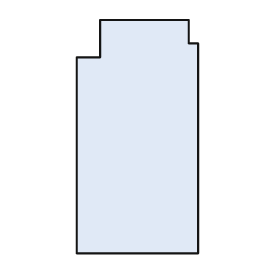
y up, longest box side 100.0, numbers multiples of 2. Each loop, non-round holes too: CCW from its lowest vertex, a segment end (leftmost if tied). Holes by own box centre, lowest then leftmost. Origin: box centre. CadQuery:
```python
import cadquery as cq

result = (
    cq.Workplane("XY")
    .moveTo(-26.0, -50.0)
    .lineTo(26.0, -50.0)
    .lineTo(26.0, 40.0)
    .lineTo(22.0, 40.0)
    .lineTo(22.0, 50.0)
    .lineTo(-16.0, 50.0)
    .lineTo(-16.0, 34.0)
    .lineTo(-26.0, 34.0)
    .close()
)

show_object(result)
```